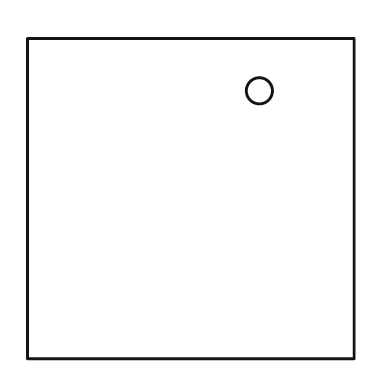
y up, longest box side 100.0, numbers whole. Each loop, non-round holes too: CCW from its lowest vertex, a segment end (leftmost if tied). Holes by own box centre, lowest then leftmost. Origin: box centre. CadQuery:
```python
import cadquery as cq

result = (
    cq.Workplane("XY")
    .moveTo(-50.0, -49.0)
    .lineTo(50.0, -49.0)
    .lineTo(50.0, 49.0)
    .lineTo(-50.0, 49.0)
    .close()
    .moveTo(21.0, 33.0)
    .circle(4.0)
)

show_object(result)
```